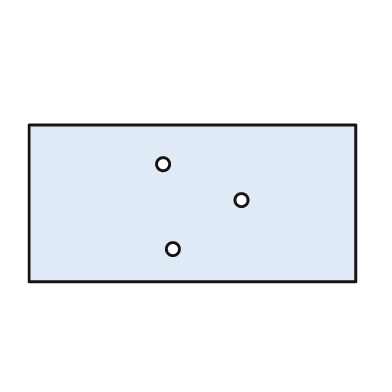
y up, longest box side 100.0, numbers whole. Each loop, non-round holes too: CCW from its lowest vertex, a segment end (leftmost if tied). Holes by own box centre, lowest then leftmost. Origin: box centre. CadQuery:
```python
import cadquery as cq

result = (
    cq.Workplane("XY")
    .moveTo(-50.0, -24.0)
    .lineTo(50.0, -24.0)
    .lineTo(50.0, 24.0)
    .lineTo(-50.0, 24.0)
    .close()
    .moveTo(-6.0, -14.0)
    .circle(2.0)
    .moveTo(15.0, 1.0)
    .circle(2.0)
    .moveTo(-9.0, 12.0)
    .circle(2.0)
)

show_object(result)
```